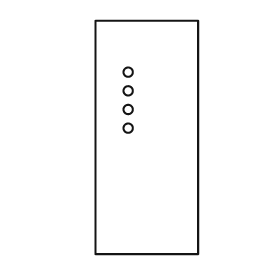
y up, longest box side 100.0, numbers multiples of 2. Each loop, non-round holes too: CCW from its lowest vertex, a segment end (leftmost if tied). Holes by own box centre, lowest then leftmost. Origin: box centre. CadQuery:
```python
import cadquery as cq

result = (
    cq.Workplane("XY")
    .moveTo(-22.0, -50.0)
    .lineTo(22.0, -50.0)
    .lineTo(22.0, 50.0)
    .lineTo(-22.0, 50.0)
    .close()
    .moveTo(-8.0, 4.0)
    .circle(2.0)
    .moveTo(-8.0, 12.0)
    .circle(2.0)
    .moveTo(-8.0, 20.0)
    .circle(2.0)
    .moveTo(-8.0, 28.0)
    .circle(2.0)
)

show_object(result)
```